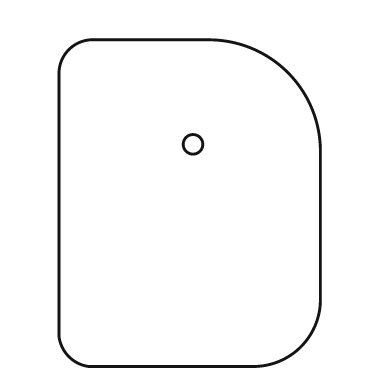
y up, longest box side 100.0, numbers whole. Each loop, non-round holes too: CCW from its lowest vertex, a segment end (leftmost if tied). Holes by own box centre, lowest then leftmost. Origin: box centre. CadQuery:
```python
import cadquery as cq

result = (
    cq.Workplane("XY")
    .moveTo(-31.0, -50.0)
    .lineTo(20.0, -50.0)
    .threePointArc((34.0, -44.0), (40.0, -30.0))
    .lineTo(40.0, 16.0)
    .threePointArc((30.0, 40.0), (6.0, 50.0))
    .lineTo(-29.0, 50.0)
    .threePointArc((-37.0, 47.0), (-40.0, 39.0))
    .lineTo(-40.0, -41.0)
    .threePointArc((-37.0, -47.0), (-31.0, -50.0))
    .close()
    .moveTo(1.0, 18.0)
    .circle(3.0)
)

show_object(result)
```